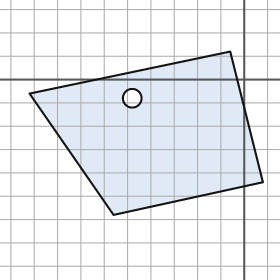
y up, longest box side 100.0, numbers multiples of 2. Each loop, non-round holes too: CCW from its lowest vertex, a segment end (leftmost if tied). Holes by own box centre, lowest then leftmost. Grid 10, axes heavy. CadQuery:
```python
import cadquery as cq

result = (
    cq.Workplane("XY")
    .moveTo(-56.0, -58.0)
    .lineTo(8.0, -44.0)
    .lineTo(-6.0, 12.0)
    .lineTo(-92.0, -6.0)
    .close()
    .moveTo(-48.0, -8.0)
    .circle(4.0)
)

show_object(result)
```